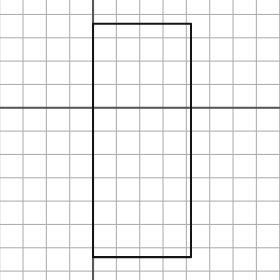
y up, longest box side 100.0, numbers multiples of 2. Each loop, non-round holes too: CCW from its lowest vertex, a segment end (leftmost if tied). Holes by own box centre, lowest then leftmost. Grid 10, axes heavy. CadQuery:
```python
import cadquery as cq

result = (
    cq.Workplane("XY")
    .moveTo(0.0, -64.0)
    .lineTo(42.0, -64.0)
    .lineTo(42.0, 36.0)
    .lineTo(0.0, 36.0)
    .close()
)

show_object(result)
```